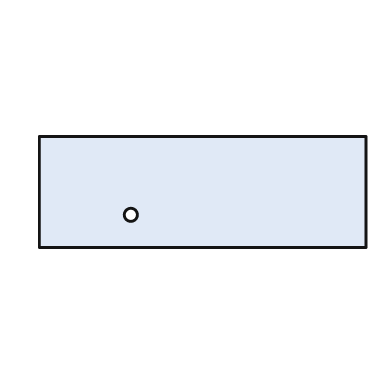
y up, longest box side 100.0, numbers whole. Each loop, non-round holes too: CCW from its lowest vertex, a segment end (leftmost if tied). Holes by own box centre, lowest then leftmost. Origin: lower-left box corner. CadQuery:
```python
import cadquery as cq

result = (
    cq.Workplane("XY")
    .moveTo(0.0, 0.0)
    .lineTo(100.0, 0.0)
    .lineTo(100.0, 34.0)
    .lineTo(0.0, 34.0)
    .close()
    .moveTo(28.0, 10.0)
    .circle(2.0)
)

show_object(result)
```